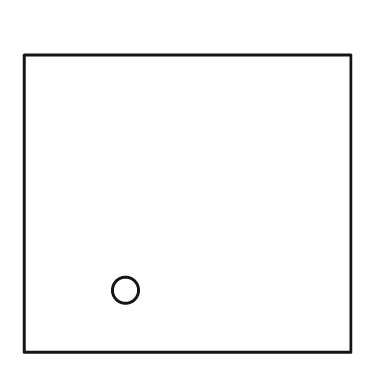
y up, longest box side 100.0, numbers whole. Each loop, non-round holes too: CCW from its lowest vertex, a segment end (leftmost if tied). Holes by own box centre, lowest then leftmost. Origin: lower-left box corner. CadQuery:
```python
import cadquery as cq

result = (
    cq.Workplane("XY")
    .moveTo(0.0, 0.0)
    .lineTo(100.0, 0.0)
    .lineTo(100.0, 91.0)
    .lineTo(0.0, 91.0)
    .close()
    .moveTo(31.0, 19.0)
    .circle(4.0)
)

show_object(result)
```